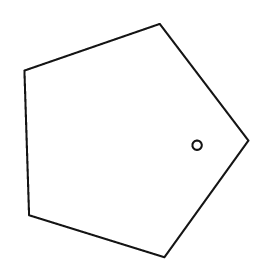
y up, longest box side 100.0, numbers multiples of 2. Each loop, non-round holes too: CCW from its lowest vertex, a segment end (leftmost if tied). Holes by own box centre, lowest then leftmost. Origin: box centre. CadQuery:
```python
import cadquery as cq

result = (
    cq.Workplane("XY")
    .moveTo(12.0, -50.0)
    .lineTo(48.0, 0.0)
    .lineTo(10.0, 50.0)
    .lineTo(-48.0, 30.0)
    .lineTo(-46.0, -32.0)
    .close()
    .moveTo(26.0, -2.0)
    .circle(2.0)
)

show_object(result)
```